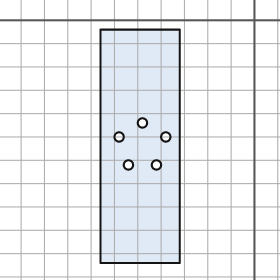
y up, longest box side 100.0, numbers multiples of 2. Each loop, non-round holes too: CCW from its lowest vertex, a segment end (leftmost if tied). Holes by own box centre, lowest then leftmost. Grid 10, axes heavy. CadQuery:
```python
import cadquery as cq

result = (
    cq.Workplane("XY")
    .moveTo(-66.0, -104.0)
    .lineTo(-32.0, -104.0)
    .lineTo(-32.0, -4.0)
    .lineTo(-66.0, -4.0)
    .close()
    .moveTo(-54.0, -62.0)
    .circle(2.0)
    .moveTo(-42.0, -62.0)
    .circle(2.0)
    .moveTo(-58.0, -50.0)
    .circle(2.0)
    .moveTo(-38.0, -50.0)
    .circle(2.0)
    .moveTo(-48.0, -44.0)
    .circle(2.0)
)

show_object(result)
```